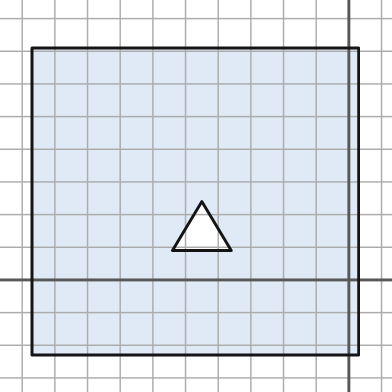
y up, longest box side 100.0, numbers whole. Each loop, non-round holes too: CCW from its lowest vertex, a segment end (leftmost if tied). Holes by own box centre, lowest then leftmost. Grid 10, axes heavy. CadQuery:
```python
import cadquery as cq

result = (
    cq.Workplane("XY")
    .moveTo(-97.0, -23.0)
    .lineTo(3.0, -23.0)
    .lineTo(3.0, 71.0)
    .lineTo(-97.0, 71.0)
    .close()
    .moveTo(-54.0, 9.0)
    .lineTo(-36.0, 9.0)
    .lineTo(-45.0, 24.0)
    .close()
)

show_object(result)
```